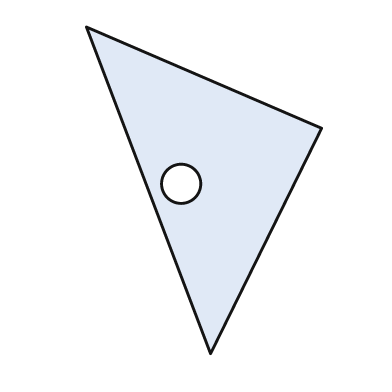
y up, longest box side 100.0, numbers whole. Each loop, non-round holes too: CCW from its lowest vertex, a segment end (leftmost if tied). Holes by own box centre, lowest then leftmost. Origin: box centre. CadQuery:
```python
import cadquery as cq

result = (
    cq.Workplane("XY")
    .moveTo(2.0, -50.0)
    .lineTo(36.0, 19.0)
    .lineTo(-36.0, 50.0)
    .close()
    .moveTo(-7.0, 2.0)
    .circle(6.0)
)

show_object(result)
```